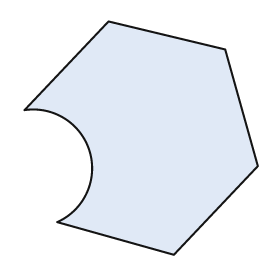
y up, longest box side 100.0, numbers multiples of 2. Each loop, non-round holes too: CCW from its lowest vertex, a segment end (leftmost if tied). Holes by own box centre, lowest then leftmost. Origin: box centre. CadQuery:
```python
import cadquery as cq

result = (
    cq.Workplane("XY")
    .moveTo(14.0, -50.0)
    .lineTo(50.0, -12.0)
    .lineTo(36.0, 38.0)
    .lineTo(-14.0, 50.0)
    .lineTo(-50.0, 12.0)
    .threePointArc((-22.0, -6.0), (-36.0, -36.0))
    .close()
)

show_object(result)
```